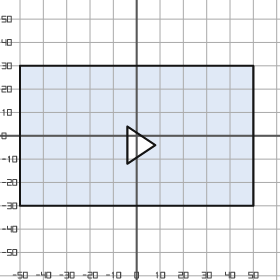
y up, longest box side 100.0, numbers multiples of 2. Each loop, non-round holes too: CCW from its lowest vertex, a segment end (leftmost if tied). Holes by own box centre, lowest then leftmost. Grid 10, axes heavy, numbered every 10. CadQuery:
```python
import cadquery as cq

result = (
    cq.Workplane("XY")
    .moveTo(-50.0, -30.0)
    .lineTo(50.0, -30.0)
    .lineTo(50.0, 30.0)
    .lineTo(-50.0, 30.0)
    .close()
    .moveTo(-4.0, -12.0)
    .lineTo(8.0, -4.0)
    .lineTo(-4.0, 4.0)
    .close()
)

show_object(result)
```